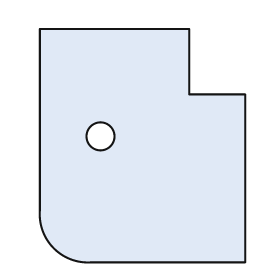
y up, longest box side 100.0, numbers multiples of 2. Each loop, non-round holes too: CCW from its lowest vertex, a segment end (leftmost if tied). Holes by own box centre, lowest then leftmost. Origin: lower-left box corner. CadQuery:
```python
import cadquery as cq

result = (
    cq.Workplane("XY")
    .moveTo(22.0, 0.0)
    .lineTo(88.0, 0.0)
    .lineTo(88.0, 72.0)
    .lineTo(64.0, 72.0)
    .lineTo(64.0, 100.0)
    .lineTo(0.0, 100.0)
    .lineTo(0.0, 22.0)
    .threePointArc((6.0, 6.0), (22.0, 0.0))
    .close()
    .moveTo(26.0, 54.0)
    .circle(6.0)
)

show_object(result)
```